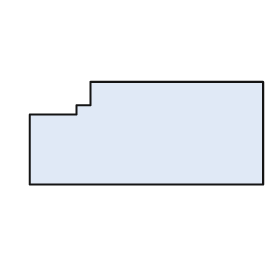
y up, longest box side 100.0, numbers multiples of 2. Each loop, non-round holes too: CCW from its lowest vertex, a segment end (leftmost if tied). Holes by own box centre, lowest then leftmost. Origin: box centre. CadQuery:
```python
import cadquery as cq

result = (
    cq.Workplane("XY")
    .moveTo(-50.0, -22.0)
    .lineTo(50.0, -22.0)
    .lineTo(50.0, 22.0)
    .lineTo(-24.0, 22.0)
    .lineTo(-24.0, 12.0)
    .lineTo(-30.0, 12.0)
    .lineTo(-30.0, 8.0)
    .lineTo(-50.0, 8.0)
    .close()
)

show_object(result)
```